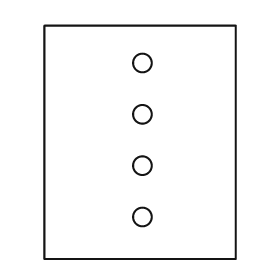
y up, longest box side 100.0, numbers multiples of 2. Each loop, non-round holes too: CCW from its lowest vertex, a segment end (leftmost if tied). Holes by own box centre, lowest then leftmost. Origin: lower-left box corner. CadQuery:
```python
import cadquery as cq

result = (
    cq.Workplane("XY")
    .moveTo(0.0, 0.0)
    .lineTo(82.0, 0.0)
    .lineTo(82.0, 100.0)
    .lineTo(0.0, 100.0)
    .close()
    .moveTo(42.0, 18.0)
    .circle(4.0)
    .moveTo(42.0, 40.0)
    .circle(4.0)
    .moveTo(42.0, 62.0)
    .circle(4.0)
    .moveTo(42.0, 84.0)
    .circle(4.0)
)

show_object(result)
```